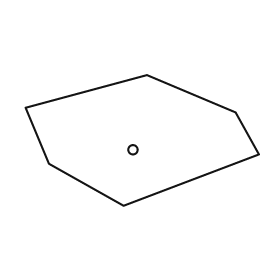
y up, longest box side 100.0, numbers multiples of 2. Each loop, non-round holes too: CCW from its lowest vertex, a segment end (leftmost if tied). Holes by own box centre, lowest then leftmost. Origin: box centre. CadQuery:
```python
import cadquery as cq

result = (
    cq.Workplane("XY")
    .moveTo(-8.0, -28.0)
    .lineTo(50.0, -6.0)
    .lineTo(40.0, 12.0)
    .lineTo(2.0, 28.0)
    .lineTo(-50.0, 14.0)
    .lineTo(-40.0, -10.0)
    .close()
    .moveTo(-4.0, -4.0)
    .circle(2.0)
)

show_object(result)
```